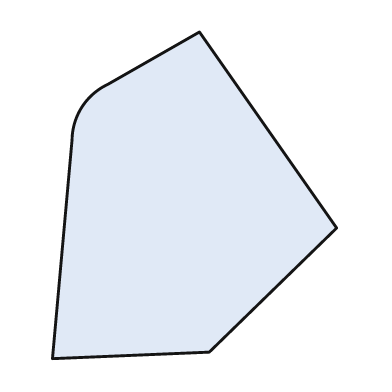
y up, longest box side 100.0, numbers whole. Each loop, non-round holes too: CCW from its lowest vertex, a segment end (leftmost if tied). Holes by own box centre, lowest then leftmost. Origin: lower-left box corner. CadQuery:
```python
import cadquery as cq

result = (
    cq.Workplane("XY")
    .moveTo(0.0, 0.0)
    .lineTo(48.0, 2.0)
    .lineTo(87.0, 40.0)
    .lineTo(45.0, 100.0)
    .lineTo(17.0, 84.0)
    .threePointArc((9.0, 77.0), (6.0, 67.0))
    .close()
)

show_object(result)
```